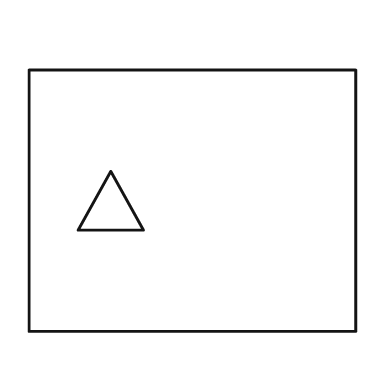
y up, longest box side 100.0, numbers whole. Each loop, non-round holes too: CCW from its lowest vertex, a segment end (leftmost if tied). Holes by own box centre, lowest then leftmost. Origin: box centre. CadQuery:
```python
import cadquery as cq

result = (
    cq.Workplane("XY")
    .moveTo(-50.0, -40.0)
    .lineTo(50.0, -40.0)
    .lineTo(50.0, 40.0)
    .lineTo(-50.0, 40.0)
    .close()
    .moveTo(-35.0, -9.0)
    .lineTo(-15.0, -9.0)
    .lineTo(-25.0, 9.0)
    .close()
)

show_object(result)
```